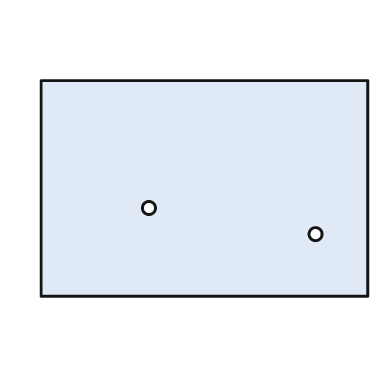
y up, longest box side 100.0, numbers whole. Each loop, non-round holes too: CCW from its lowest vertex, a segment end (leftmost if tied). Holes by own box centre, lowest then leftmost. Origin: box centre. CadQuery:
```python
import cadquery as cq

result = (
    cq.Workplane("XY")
    .moveTo(-50.0, -33.0)
    .lineTo(50.0, -33.0)
    .lineTo(50.0, 33.0)
    .lineTo(-50.0, 33.0)
    .close()
    .moveTo(34.0, -14.0)
    .circle(2.0)
    .moveTo(-17.0, -6.0)
    .circle(2.0)
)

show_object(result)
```